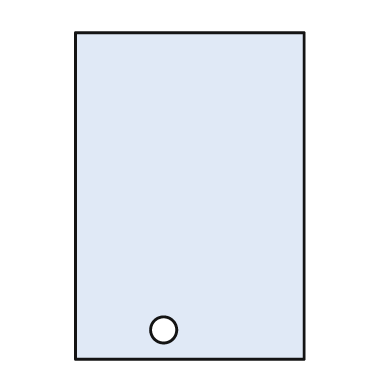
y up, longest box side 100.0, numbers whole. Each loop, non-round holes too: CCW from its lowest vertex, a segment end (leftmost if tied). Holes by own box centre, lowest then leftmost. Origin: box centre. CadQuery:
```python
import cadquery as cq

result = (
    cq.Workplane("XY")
    .moveTo(-35.0, -50.0)
    .lineTo(35.0, -50.0)
    .lineTo(35.0, 50.0)
    .lineTo(-35.0, 50.0)
    .close()
    .moveTo(-8.0, -41.0)
    .circle(4.0)
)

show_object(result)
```